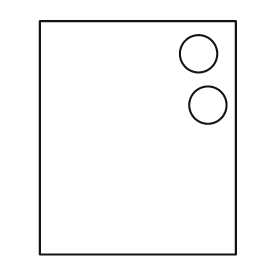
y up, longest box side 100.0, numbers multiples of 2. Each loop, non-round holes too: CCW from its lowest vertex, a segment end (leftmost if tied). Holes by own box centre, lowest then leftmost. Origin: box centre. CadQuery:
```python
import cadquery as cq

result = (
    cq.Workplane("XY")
    .moveTo(-42.0, -50.0)
    .lineTo(42.0, -50.0)
    .lineTo(42.0, 50.0)
    .lineTo(-42.0, 50.0)
    .close()
    .moveTo(30.0, 14.0)
    .circle(8.0)
    .moveTo(26.0, 36.0)
    .circle(8.0)
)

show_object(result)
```